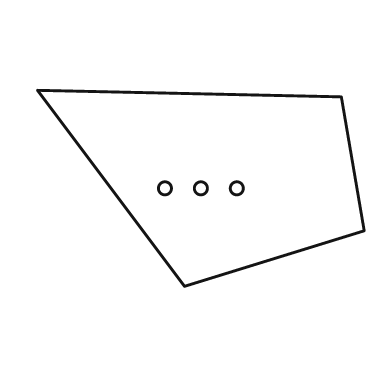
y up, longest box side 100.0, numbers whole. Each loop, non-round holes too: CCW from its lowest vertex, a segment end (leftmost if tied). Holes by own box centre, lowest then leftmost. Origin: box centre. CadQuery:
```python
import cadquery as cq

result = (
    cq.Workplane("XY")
    .moveTo(-5.0, -30.0)
    .lineTo(50.0, -13.0)
    .lineTo(43.0, 28.0)
    .lineTo(-50.0, 30.0)
    .close()
    .moveTo(-11.0, 0.0)
    .circle(2.0)
    .moveTo(0.0, 0.0)
    .circle(2.0)
    .moveTo(11.0, 0.0)
    .circle(2.0)
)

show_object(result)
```